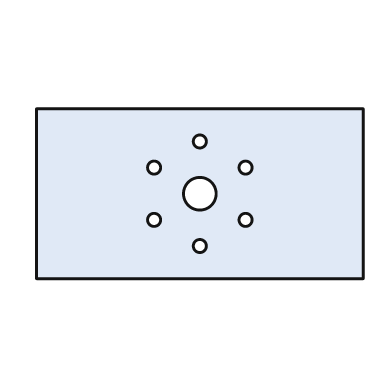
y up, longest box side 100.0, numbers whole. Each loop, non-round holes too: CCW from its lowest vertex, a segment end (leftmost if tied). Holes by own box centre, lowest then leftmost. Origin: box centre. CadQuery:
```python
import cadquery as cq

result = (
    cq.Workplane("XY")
    .moveTo(-50.0, -26.0)
    .lineTo(50.0, -26.0)
    .lineTo(50.0, 26.0)
    .lineTo(-50.0, 26.0)
    .close()
    .moveTo(0.0, -16.0)
    .circle(2.0)
    .moveTo(-14.0, -8.0)
    .circle(2.0)
    .moveTo(14.0, -8.0)
    .circle(2.0)
    .moveTo(0.0, 0.0)
    .circle(5.0)
    .moveTo(-14.0, 8.0)
    .circle(2.0)
    .moveTo(14.0, 8.0)
    .circle(2.0)
    .moveTo(0.0, 16.0)
    .circle(2.0)
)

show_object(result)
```